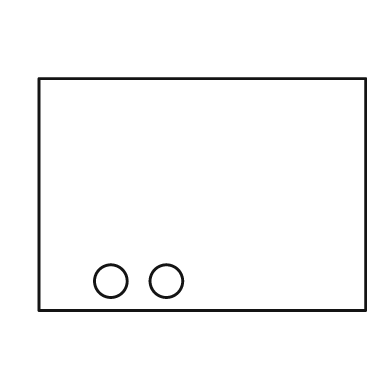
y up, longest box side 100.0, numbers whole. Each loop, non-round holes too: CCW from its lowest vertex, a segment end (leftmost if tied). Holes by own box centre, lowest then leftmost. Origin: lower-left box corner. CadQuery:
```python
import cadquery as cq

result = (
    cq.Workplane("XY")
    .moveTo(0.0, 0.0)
    .lineTo(100.0, 0.0)
    .lineTo(100.0, 71.0)
    .lineTo(0.0, 71.0)
    .close()
    .moveTo(22.0, 9.0)
    .circle(5.0)
    .moveTo(39.0, 9.0)
    .circle(5.0)
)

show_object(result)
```